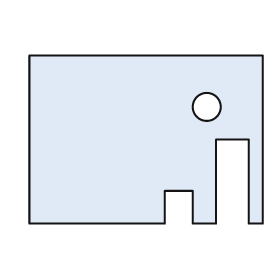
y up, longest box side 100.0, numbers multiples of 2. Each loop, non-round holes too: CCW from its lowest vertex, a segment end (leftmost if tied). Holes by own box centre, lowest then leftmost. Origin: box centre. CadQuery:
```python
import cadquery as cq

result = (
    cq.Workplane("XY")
    .moveTo(-50.0, -36.0)
    .lineTo(8.0, -36.0)
    .lineTo(8.0, -22.0)
    .lineTo(20.0, -22.0)
    .lineTo(20.0, -36.0)
    .lineTo(30.0, -36.0)
    .lineTo(30.0, 0.0)
    .lineTo(44.0, 0.0)
    .lineTo(44.0, -36.0)
    .lineTo(50.0, -36.0)
    .lineTo(50.0, 36.0)
    .lineTo(-50.0, 36.0)
    .close()
    .moveTo(26.0, 14.0)
    .circle(6.0)
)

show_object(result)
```